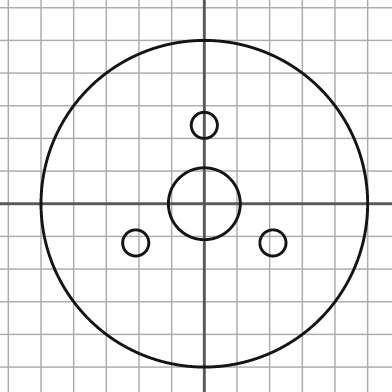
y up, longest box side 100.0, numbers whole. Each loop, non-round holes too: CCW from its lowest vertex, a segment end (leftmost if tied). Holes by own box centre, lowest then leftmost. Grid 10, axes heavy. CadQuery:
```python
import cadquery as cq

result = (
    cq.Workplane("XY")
    .moveTo(0.0, 0.0)
    .circle(50.0)
    .moveTo(-21.0, -12.0)
    .circle(4.0)
    .moveTo(21.0, -12.0)
    .circle(4.0)
    .moveTo(0.0, 0.0)
    .circle(11.0)
    .moveTo(0.0, 24.0)
    .circle(4.0)
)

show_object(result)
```